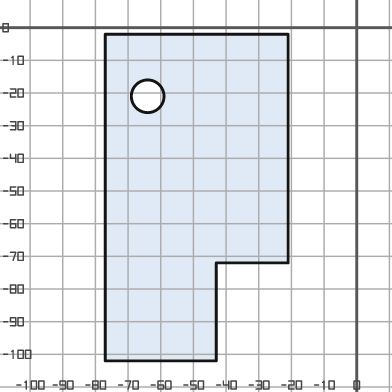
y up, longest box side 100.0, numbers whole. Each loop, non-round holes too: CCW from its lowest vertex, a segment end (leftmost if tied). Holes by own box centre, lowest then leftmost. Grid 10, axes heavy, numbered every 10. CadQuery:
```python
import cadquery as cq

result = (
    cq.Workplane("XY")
    .moveTo(-77.0, -102.0)
    .lineTo(-43.0, -102.0)
    .lineTo(-43.0, -72.0)
    .lineTo(-21.0, -72.0)
    .lineTo(-21.0, -2.0)
    .lineTo(-77.0, -2.0)
    .close()
    .moveTo(-64.0, -21.0)
    .circle(5.0)
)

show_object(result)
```